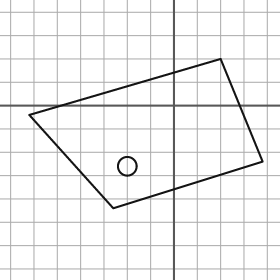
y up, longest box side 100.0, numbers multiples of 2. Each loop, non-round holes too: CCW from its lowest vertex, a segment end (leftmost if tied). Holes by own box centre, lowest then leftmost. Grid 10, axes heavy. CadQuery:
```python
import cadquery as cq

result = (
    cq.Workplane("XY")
    .moveTo(-26.0, -44.0)
    .lineTo(38.0, -24.0)
    .lineTo(20.0, 20.0)
    .lineTo(-62.0, -4.0)
    .close()
    .moveTo(-20.0, -26.0)
    .circle(4.0)
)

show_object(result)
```